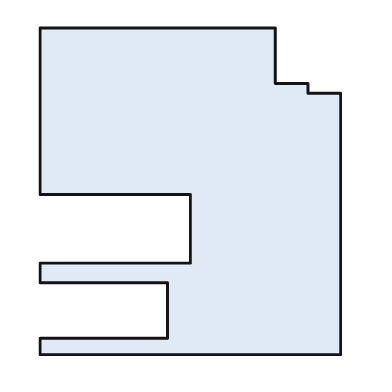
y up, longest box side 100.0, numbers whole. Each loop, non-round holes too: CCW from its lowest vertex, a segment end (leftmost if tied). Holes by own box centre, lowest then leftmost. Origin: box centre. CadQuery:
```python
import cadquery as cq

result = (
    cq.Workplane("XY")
    .moveTo(-46.0, -50.0)
    .lineTo(46.0, -50.0)
    .lineTo(46.0, 30.0)
    .lineTo(36.0, 30.0)
    .lineTo(36.0, 33.0)
    .lineTo(26.0, 33.0)
    .lineTo(26.0, 50.0)
    .lineTo(-46.0, 50.0)
    .lineTo(-46.0, -1.0)
    .lineTo(0.0, -1.0)
    .lineTo(0.0, -22.0)
    .lineTo(-46.0, -22.0)
    .lineTo(-46.0, -28.0)
    .lineTo(-7.0, -28.0)
    .lineTo(-7.0, -45.0)
    .lineTo(-46.0, -45.0)
    .close()
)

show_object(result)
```